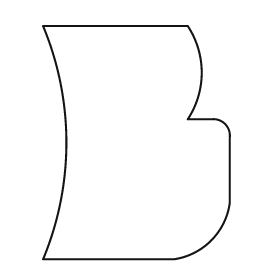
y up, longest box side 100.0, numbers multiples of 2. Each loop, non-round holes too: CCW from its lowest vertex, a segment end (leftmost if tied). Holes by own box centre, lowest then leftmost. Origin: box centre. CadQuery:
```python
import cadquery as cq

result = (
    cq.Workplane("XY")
    .moveTo(-40.0, -50.0)
    .lineTo(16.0, -50.0)
    .threePointArc((32.0, -42.0), (40.0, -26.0))
    .lineTo(40.0, 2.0)
    .threePointArc((38.0, 8.0), (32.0, 10.0))
    .lineTo(22.0, 10.0)
    .threePointArc((28.0, 30.0), (22.0, 50.0))
    .lineTo(-40.0, 50.0)
    .threePointArc((-30.0, 0.0), (-40.0, -50.0))
    .close()
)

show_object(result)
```